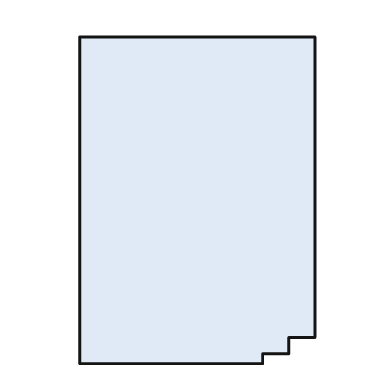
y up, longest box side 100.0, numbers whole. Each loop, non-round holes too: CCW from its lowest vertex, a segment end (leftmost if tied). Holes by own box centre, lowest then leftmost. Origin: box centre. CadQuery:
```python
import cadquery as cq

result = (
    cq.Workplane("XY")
    .moveTo(-36.0, -50.0)
    .lineTo(20.0, -50.0)
    .lineTo(20.0, -47.0)
    .lineTo(28.0, -47.0)
    .lineTo(28.0, -42.0)
    .lineTo(36.0, -42.0)
    .lineTo(36.0, 50.0)
    .lineTo(-36.0, 50.0)
    .close()
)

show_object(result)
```